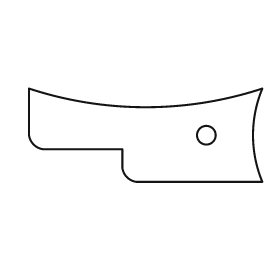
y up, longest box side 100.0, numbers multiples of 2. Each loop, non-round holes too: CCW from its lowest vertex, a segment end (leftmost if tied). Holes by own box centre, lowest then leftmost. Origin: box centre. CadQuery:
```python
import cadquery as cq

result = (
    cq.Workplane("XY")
    .moveTo(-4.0, -20.0)
    .lineTo(50.0, -20.0)
    .threePointArc((46.0, 0.0), (50.0, 20.0))
    .threePointArc((0.0, 12.0), (-50.0, 20.0))
    .lineTo(-50.0, 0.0)
    .threePointArc((-48.0, -4.0), (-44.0, -6.0))
    .lineTo(-10.0, -6.0)
    .lineTo(-10.0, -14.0)
    .threePointArc((-8.0, -18.0), (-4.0, -20.0))
    .close()
    .moveTo(26.0, 0.0)
    .circle(4.0)
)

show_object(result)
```